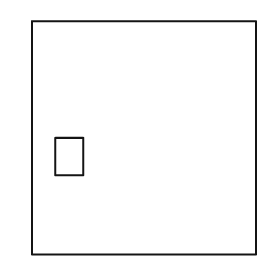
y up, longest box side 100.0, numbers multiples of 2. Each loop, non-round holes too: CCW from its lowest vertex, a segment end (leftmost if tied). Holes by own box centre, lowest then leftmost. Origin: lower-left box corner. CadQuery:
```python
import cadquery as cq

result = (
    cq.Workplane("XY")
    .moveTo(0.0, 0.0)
    .lineTo(96.0, 0.0)
    .lineTo(96.0, 100.0)
    .lineTo(0.0, 100.0)
    .close()
    .moveTo(10.0, 34.0)
    .lineTo(22.0, 34.0)
    .lineTo(22.0, 50.0)
    .lineTo(10.0, 50.0)
    .close()
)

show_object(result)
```